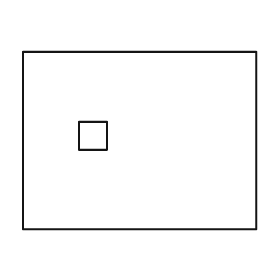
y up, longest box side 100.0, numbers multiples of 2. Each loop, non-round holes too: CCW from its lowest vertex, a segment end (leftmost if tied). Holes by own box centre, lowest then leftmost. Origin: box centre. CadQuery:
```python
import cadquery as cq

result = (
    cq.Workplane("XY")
    .moveTo(-50.0, -38.0)
    .lineTo(50.0, -38.0)
    .lineTo(50.0, 38.0)
    .lineTo(-50.0, 38.0)
    .close()
    .moveTo(-26.0, -4.0)
    .lineTo(-14.0, -4.0)
    .lineTo(-14.0, 8.0)
    .lineTo(-26.0, 8.0)
    .close()
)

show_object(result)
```